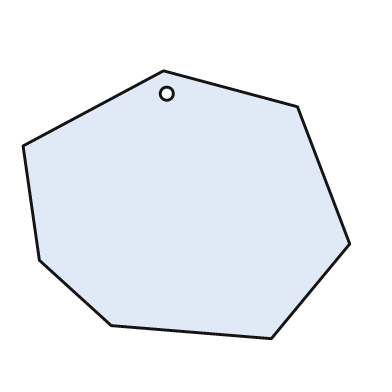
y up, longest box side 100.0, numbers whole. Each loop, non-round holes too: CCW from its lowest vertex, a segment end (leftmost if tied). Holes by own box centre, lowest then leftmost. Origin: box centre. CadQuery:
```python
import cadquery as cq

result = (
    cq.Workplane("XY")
    .moveTo(26.0, -41.0)
    .lineTo(50.0, -12.0)
    .lineTo(34.0, 30.0)
    .lineTo(-7.0, 41.0)
    .lineTo(-50.0, 18.0)
    .lineTo(-45.0, -17.0)
    .lineTo(-23.0, -37.0)
    .close()
    .moveTo(-6.0, 34.0)
    .circle(2.0)
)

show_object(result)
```